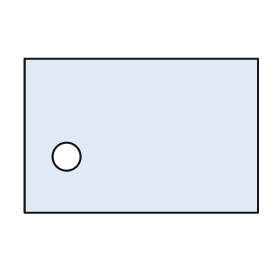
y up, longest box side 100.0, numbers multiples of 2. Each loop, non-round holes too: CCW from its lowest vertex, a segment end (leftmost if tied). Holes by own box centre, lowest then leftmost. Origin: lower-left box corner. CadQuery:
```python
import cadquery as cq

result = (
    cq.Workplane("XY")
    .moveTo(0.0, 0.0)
    .lineTo(100.0, 0.0)
    .lineTo(100.0, 66.0)
    .lineTo(0.0, 66.0)
    .close()
    .moveTo(18.0, 24.0)
    .circle(6.0)
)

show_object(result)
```